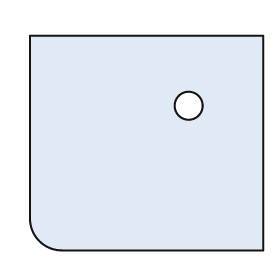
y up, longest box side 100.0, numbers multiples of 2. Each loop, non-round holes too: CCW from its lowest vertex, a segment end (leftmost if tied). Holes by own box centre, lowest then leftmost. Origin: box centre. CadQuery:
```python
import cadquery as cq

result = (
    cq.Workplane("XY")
    .moveTo(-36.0, -46.0)
    .lineTo(50.0, -46.0)
    .lineTo(50.0, 46.0)
    .lineTo(-50.0, 46.0)
    .lineTo(-50.0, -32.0)
    .threePointArc((-46.0, -42.0), (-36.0, -46.0))
    .close()
    .moveTo(18.0, 16.0)
    .circle(6.0)
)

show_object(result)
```